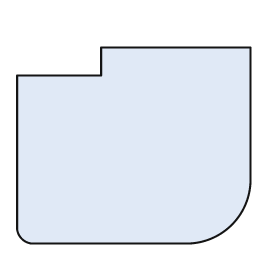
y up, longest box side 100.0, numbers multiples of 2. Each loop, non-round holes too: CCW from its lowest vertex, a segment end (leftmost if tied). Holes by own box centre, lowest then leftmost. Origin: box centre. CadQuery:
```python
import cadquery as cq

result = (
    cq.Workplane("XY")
    .moveTo(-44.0, -42.0)
    .lineTo(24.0, -42.0)
    .threePointArc((42.0, -34.0), (50.0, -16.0))
    .lineTo(50.0, 42.0)
    .lineTo(-14.0, 42.0)
    .lineTo(-14.0, 30.0)
    .lineTo(-50.0, 30.0)
    .lineTo(-50.0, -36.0)
    .threePointArc((-48.0, -40.0), (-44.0, -42.0))
    .close()
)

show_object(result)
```